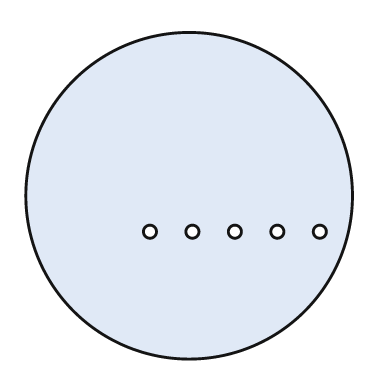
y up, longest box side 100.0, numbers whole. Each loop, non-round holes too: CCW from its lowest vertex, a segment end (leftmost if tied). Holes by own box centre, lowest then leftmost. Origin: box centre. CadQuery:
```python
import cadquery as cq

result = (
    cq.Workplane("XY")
    .moveTo(0.0, 0.0)
    .circle(50.0)
    .moveTo(-12.0, -11.0)
    .circle(2.0)
    .moveTo(1.0, -11.0)
    .circle(2.0)
    .moveTo(14.0, -11.0)
    .circle(2.0)
    .moveTo(27.0, -11.0)
    .circle(2.0)
    .moveTo(40.0, -11.0)
    .circle(2.0)
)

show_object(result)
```